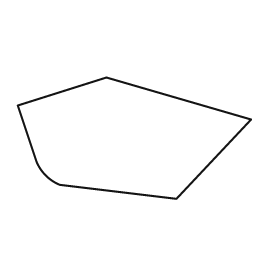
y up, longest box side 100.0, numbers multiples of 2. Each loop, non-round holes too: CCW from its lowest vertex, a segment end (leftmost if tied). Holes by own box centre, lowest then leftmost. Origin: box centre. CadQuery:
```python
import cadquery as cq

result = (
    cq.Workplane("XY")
    .moveTo(18.0, -26.0)
    .lineTo(50.0, 8.0)
    .lineTo(-12.0, 26.0)
    .lineTo(-50.0, 14.0)
    .lineTo(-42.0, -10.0)
    .threePointArc((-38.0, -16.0), (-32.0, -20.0))
    .close()
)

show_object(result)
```